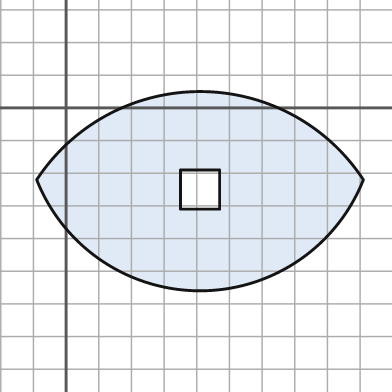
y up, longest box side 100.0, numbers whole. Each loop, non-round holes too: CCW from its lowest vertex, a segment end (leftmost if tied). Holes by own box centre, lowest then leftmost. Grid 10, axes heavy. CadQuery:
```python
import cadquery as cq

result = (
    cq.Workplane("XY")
    .moveTo(-9.0, -22.0)
    .threePointArc((41.0, -56.0), (91.0, -22.0))
    .threePointArc((41.0, 5.0), (-9.0, -22.0))
    .close()
    .moveTo(35.0, -31.0)
    .lineTo(47.0, -31.0)
    .lineTo(47.0, -19.0)
    .lineTo(35.0, -19.0)
    .close()
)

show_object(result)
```